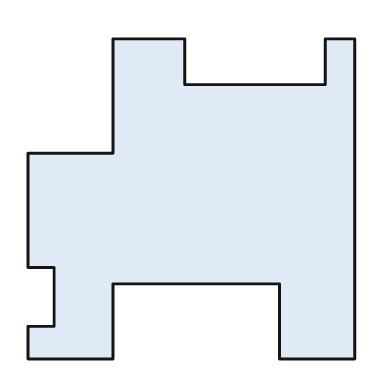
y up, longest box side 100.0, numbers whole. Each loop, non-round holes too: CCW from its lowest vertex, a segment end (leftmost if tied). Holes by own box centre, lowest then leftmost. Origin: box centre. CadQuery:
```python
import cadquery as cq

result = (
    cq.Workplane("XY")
    .moveTo(-50.0, -49.0)
    .lineTo(-24.0, -49.0)
    .lineTo(-24.0, -26.0)
    .lineTo(27.0, -26.0)
    .lineTo(27.0, -49.0)
    .lineTo(50.0, -49.0)
    .lineTo(50.0, 49.0)
    .lineTo(41.0, 49.0)
    .lineTo(41.0, 35.0)
    .lineTo(-2.0, 35.0)
    .lineTo(-2.0, 49.0)
    .lineTo(-24.0, 49.0)
    .lineTo(-24.0, 14.0)
    .lineTo(-50.0, 14.0)
    .lineTo(-50.0, -21.0)
    .lineTo(-42.0, -21.0)
    .lineTo(-42.0, -39.0)
    .lineTo(-50.0, -39.0)
    .close()
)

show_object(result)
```